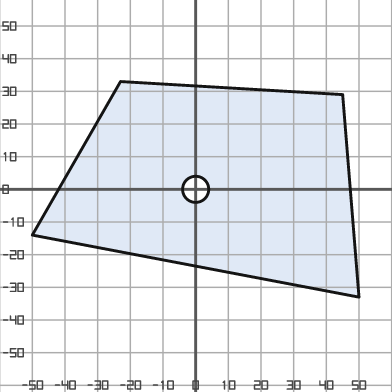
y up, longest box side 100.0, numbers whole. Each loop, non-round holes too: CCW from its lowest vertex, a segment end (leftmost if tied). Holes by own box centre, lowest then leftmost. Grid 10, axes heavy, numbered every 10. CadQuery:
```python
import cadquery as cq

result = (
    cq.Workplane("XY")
    .moveTo(50.0, -33.0)
    .lineTo(45.0, 29.0)
    .lineTo(-23.0, 33.0)
    .lineTo(-50.0, -14.0)
    .close()
    .moveTo(0.0, 0.0)
    .circle(4.0)
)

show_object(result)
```